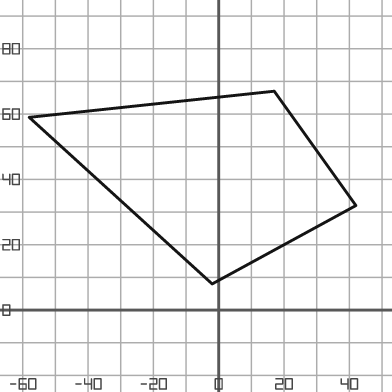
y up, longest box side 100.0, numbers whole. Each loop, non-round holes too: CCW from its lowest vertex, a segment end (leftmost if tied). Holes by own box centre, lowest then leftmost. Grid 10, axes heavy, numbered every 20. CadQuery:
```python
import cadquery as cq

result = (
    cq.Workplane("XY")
    .moveTo(-2.0, 8.0)
    .lineTo(42.0, 32.0)
    .lineTo(17.0, 67.0)
    .lineTo(-58.0, 59.0)
    .close()
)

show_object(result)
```